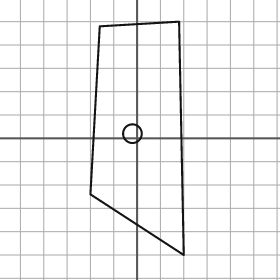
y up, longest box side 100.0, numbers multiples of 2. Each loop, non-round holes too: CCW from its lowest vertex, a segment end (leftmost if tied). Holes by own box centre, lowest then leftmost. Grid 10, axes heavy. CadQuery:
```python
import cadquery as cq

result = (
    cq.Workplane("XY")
    .moveTo(20.0, -50.0)
    .lineTo(18.0, 50.0)
    .lineTo(-16.0, 48.0)
    .lineTo(-20.0, -24.0)
    .close()
    .moveTo(-2.0, 2.0)
    .circle(4.0)
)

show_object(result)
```